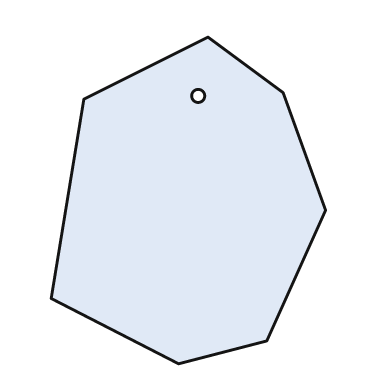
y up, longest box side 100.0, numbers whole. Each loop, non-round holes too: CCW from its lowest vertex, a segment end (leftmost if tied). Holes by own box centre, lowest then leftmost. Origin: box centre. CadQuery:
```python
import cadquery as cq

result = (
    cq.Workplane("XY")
    .moveTo(-3.0, -50.0)
    .lineTo(24.0, -43.0)
    .lineTo(42.0, -3.0)
    .lineTo(29.0, 33.0)
    .lineTo(6.0, 50.0)
    .lineTo(-32.0, 31.0)
    .lineTo(-42.0, -30.0)
    .close()
    .moveTo(3.0, 32.0)
    .circle(2.0)
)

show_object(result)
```